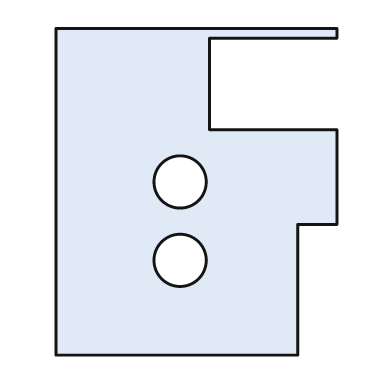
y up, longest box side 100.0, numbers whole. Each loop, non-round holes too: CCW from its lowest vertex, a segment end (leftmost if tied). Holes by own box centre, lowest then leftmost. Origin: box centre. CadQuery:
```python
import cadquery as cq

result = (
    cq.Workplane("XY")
    .moveTo(-43.0, -50.0)
    .lineTo(31.0, -50.0)
    .lineTo(31.0, -10.0)
    .lineTo(43.0, -10.0)
    .lineTo(43.0, 19.0)
    .lineTo(4.0, 19.0)
    .lineTo(4.0, 47.0)
    .lineTo(43.0, 47.0)
    .lineTo(43.0, 50.0)
    .lineTo(-43.0, 50.0)
    .close()
    .moveTo(-5.0, -21.0)
    .circle(8.0)
    .moveTo(-5.0, 3.0)
    .circle(8.0)
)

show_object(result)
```